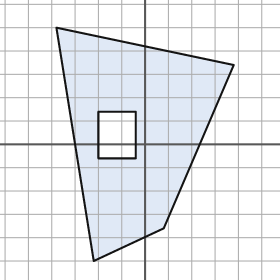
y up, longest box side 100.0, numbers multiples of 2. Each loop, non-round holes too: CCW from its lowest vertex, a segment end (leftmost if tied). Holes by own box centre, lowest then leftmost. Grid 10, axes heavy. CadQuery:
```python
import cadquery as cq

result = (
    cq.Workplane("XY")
    .moveTo(-22.0, -50.0)
    .lineTo(8.0, -36.0)
    .lineTo(38.0, 34.0)
    .lineTo(-38.0, 50.0)
    .close()
    .moveTo(-20.0, -6.0)
    .lineTo(-4.0, -6.0)
    .lineTo(-4.0, 14.0)
    .lineTo(-20.0, 14.0)
    .close()
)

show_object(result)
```